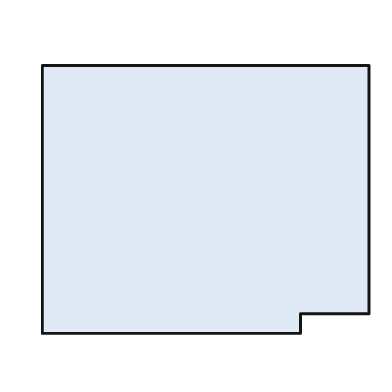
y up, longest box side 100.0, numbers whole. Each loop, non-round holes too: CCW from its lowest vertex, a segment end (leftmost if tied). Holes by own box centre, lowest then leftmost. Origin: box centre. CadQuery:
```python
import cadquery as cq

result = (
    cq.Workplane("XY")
    .moveTo(-50.0, -41.0)
    .lineTo(29.0, -41.0)
    .lineTo(29.0, -35.0)
    .lineTo(50.0, -35.0)
    .lineTo(50.0, 41.0)
    .lineTo(-50.0, 41.0)
    .close()
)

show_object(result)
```